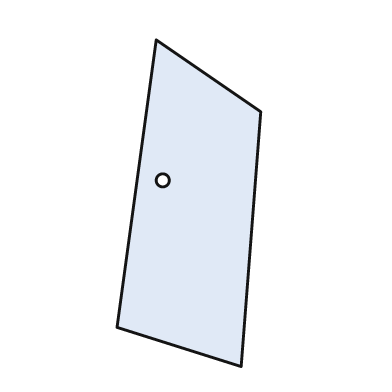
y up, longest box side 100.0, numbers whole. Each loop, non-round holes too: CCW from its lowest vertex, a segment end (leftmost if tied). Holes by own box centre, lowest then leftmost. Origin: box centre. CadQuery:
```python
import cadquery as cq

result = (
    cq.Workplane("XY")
    .moveTo(16.0, -50.0)
    .lineTo(22.0, 28.0)
    .lineTo(-10.0, 50.0)
    .lineTo(-22.0, -38.0)
    .close()
    .moveTo(-8.0, 7.0)
    .circle(2.0)
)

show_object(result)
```